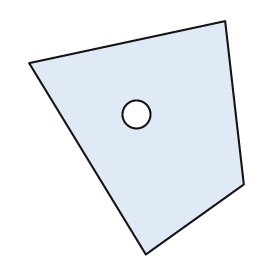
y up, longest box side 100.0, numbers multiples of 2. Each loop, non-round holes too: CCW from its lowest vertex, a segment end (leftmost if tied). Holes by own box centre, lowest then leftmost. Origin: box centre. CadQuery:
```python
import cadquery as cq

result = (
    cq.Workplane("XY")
    .moveTo(4.0, -50.0)
    .lineTo(46.0, -20.0)
    .lineTo(38.0, 50.0)
    .lineTo(-46.0, 32.0)
    .close()
    .moveTo(0.0, 10.0)
    .circle(6.0)
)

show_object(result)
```